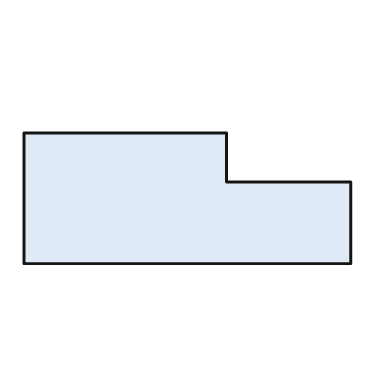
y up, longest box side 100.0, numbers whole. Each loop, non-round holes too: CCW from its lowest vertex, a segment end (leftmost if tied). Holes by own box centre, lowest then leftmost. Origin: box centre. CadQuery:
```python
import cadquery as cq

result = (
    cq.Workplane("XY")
    .moveTo(-50.0, -20.0)
    .lineTo(50.0, -20.0)
    .lineTo(50.0, 5.0)
    .lineTo(12.0, 5.0)
    .lineTo(12.0, 20.0)
    .lineTo(-50.0, 20.0)
    .close()
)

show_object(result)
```